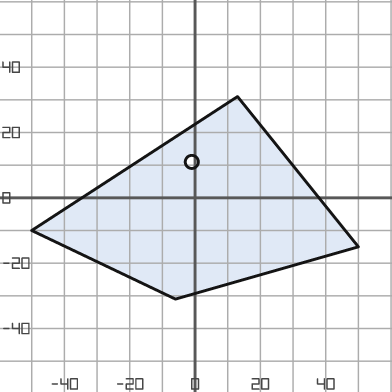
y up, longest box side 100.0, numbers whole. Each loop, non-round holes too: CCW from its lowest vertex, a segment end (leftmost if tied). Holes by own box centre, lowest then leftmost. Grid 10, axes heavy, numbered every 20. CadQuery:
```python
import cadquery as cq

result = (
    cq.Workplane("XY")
    .moveTo(-6.0, -31.0)
    .lineTo(50.0, -15.0)
    .lineTo(13.0, 31.0)
    .lineTo(-50.0, -10.0)
    .close()
    .moveTo(-1.0, 11.0)
    .circle(2.0)
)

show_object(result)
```